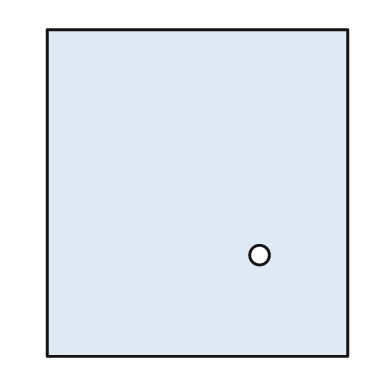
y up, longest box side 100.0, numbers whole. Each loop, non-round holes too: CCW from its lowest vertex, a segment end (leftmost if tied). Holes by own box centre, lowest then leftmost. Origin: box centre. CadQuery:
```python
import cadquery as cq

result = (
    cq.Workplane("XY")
    .moveTo(-46.0, -50.0)
    .lineTo(46.0, -50.0)
    .lineTo(46.0, 50.0)
    .lineTo(-46.0, 50.0)
    .close()
    .moveTo(19.0, -19.0)
    .circle(3.0)
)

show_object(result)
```